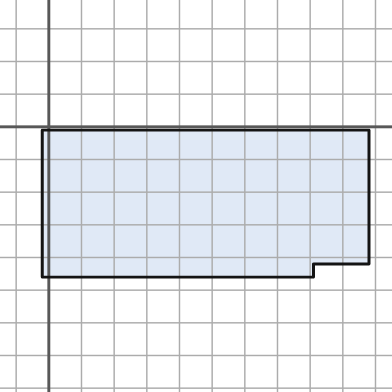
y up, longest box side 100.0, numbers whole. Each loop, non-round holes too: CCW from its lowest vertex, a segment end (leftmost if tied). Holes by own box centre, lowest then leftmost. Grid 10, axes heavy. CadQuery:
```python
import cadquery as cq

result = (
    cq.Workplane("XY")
    .moveTo(-2.0, -46.0)
    .lineTo(81.0, -46.0)
    .lineTo(81.0, -42.0)
    .lineTo(98.0, -42.0)
    .lineTo(98.0, -1.0)
    .lineTo(-2.0, -1.0)
    .close()
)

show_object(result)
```